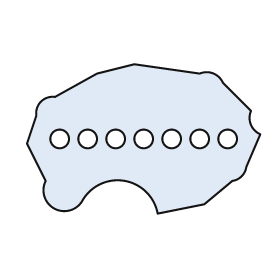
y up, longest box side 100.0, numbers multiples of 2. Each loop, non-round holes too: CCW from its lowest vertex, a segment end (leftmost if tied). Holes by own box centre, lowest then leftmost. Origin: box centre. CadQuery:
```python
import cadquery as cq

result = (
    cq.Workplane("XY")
    .moveTo(6.0, -32.0)
    .lineTo(26.0, -28.0)
    .lineTo(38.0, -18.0)
    .threePointArc((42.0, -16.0), (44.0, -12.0))
    .lineTo(50.0, 2.0)
    .threePointArc((46.0, 6.0), (46.0, 12.0))
    .lineTo(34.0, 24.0)
    .threePointArc((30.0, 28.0), (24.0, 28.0))
    .lineTo(-4.0, 32.0)
    .lineTo(-20.0, 28.0)
    .lineTo(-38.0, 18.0)
    .threePointArc((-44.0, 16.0), (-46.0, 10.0))
    .lineTo(-50.0, -2.0)
    .lineTo(-42.0, -18.0)
    .threePointArc((-38.0, -30.0), (-26.0, -26.0))
    .threePointArc((-8.0, -18.0), (6.0, -32.0))
    .close()
    .moveTo(-36.0, 0.0)
    .circle(4.0)
    .moveTo(-24.0, 0.0)
    .circle(4.0)
    .moveTo(-12.0, 0.0)
    .circle(4.0)
    .moveTo(0.0, 0.0)
    .circle(4.0)
    .moveTo(12.0, 0.0)
    .circle(4.0)
    .moveTo(24.0, 0.0)
    .circle(4.0)
    .moveTo(36.0, 0.0)
    .circle(4.0)
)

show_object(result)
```